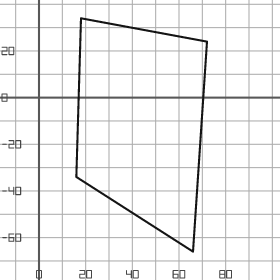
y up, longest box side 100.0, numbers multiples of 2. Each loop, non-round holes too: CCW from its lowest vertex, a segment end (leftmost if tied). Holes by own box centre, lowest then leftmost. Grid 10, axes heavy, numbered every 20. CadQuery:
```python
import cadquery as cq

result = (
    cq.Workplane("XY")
    .moveTo(66.0, -66.0)
    .lineTo(72.0, 24.0)
    .lineTo(18.0, 34.0)
    .lineTo(16.0, -34.0)
    .close()
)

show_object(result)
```